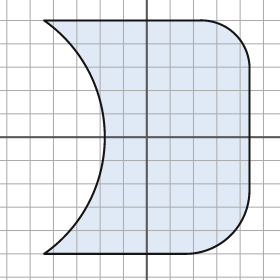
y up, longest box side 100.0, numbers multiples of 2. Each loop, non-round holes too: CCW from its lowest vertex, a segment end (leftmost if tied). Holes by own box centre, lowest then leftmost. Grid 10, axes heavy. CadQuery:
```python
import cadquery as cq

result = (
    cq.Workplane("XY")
    .moveTo(-44.0, -50.0)
    .lineTo(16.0, -50.0)
    .threePointArc((36.0, -42.0), (44.0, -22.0))
    .lineTo(44.0, 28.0)
    .threePointArc((38.0, 44.0), (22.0, 50.0))
    .lineTo(-44.0, 50.0)
    .threePointArc((-18.0, 0.0), (-44.0, -50.0))
    .close()
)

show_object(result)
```